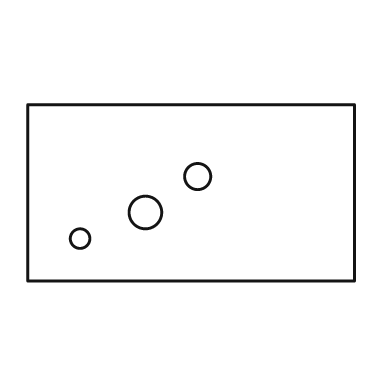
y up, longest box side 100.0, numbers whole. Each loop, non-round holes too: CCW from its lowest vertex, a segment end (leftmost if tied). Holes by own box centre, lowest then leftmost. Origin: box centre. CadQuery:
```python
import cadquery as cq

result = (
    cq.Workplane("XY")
    .moveTo(-50.0, -27.0)
    .lineTo(50.0, -27.0)
    .lineTo(50.0, 27.0)
    .lineTo(-50.0, 27.0)
    .close()
    .moveTo(-34.0, -14.0)
    .circle(3.0)
    .moveTo(-14.0, -6.0)
    .circle(5.0)
    .moveTo(2.0, 5.0)
    .circle(4.0)
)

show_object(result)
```